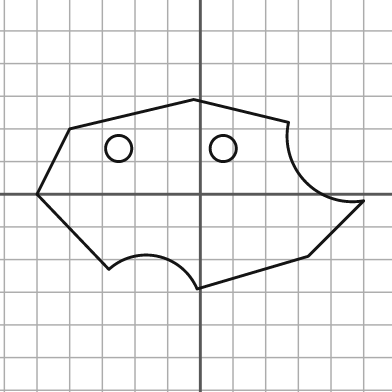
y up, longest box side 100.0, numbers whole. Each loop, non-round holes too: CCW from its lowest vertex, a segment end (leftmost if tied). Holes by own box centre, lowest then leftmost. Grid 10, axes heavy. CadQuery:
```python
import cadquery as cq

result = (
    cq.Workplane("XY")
    .moveTo(-1.0, -29.0)
    .lineTo(33.0, -19.0)
    .lineTo(50.0, -2.0)
    .threePointArc((32.0, 4.0), (27.0, 22.0))
    .lineTo(-2.0, 29.0)
    .lineTo(-40.0, 20.0)
    .lineTo(-50.0, 0.0)
    .lineTo(-28.0, -23.0)
    .threePointArc((-13.0, -19.0), (-1.0, -29.0))
    .close()
    .moveTo(-25.0, 14.0)
    .circle(4.0)
    .moveTo(7.0, 14.0)
    .circle(4.0)
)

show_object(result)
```